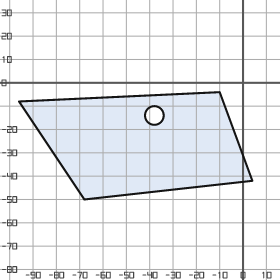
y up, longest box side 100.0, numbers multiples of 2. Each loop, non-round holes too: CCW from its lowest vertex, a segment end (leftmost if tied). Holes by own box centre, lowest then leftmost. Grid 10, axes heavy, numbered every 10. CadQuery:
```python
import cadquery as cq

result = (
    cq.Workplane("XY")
    .moveTo(-68.0, -50.0)
    .lineTo(4.0, -42.0)
    .lineTo(-10.0, -4.0)
    .lineTo(-96.0, -8.0)
    .close()
    .moveTo(-38.0, -14.0)
    .circle(4.0)
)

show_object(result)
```